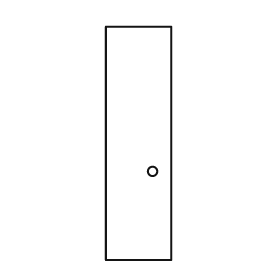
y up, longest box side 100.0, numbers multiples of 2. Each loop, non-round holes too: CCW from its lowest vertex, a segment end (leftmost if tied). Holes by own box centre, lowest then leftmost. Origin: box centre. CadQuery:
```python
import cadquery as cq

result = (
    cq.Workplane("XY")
    .moveTo(-14.0, -50.0)
    .lineTo(14.0, -50.0)
    .lineTo(14.0, 50.0)
    .lineTo(-14.0, 50.0)
    .close()
    .moveTo(6.0, -12.0)
    .circle(2.0)
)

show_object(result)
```